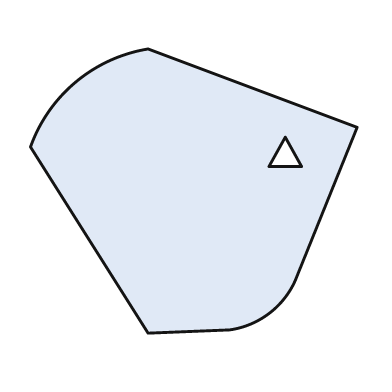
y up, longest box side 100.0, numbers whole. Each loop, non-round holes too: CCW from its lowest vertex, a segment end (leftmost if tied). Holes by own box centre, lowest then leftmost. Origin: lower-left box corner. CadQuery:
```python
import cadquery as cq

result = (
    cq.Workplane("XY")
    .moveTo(36.0, 0.0)
    .lineTo(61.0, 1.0)
    .threePointArc((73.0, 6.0), (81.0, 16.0))
    .lineTo(100.0, 63.0)
    .lineTo(36.0, 87.0)
    .threePointArc((14.0, 77.0), (0.0, 57.0))
    .close()
    .moveTo(73.0, 51.0)
    .lineTo(83.0, 51.0)
    .lineTo(78.0, 60.0)
    .close()
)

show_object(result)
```